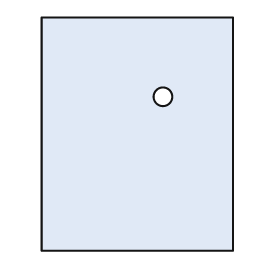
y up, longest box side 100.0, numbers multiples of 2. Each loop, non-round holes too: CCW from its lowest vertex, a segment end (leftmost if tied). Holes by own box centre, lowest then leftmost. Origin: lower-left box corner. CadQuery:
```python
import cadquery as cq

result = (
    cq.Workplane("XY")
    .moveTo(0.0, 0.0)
    .lineTo(82.0, 0.0)
    .lineTo(82.0, 100.0)
    .lineTo(0.0, 100.0)
    .close()
    .moveTo(52.0, 66.0)
    .circle(4.0)
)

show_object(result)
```